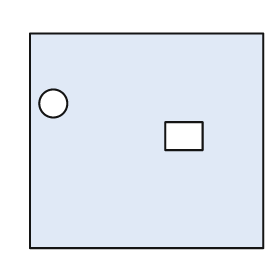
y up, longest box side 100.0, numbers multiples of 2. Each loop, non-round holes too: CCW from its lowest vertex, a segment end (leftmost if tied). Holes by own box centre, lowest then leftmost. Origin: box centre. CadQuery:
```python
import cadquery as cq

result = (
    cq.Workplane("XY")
    .moveTo(-50.0, -46.0)
    .lineTo(50.0, -46.0)
    .lineTo(50.0, 46.0)
    .lineTo(-50.0, 46.0)
    .close()
    .moveTo(8.0, -4.0)
    .lineTo(24.0, -4.0)
    .lineTo(24.0, 8.0)
    .lineTo(8.0, 8.0)
    .close()
    .moveTo(-40.0, 16.0)
    .circle(6.0)
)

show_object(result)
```